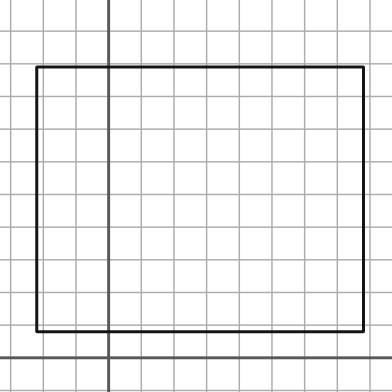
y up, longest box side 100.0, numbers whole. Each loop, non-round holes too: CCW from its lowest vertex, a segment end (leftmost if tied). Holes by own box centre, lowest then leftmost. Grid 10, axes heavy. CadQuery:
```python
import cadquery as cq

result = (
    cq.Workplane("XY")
    .moveTo(-22.0, 8.0)
    .lineTo(78.0, 8.0)
    .lineTo(78.0, 89.0)
    .lineTo(-22.0, 89.0)
    .close()
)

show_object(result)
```